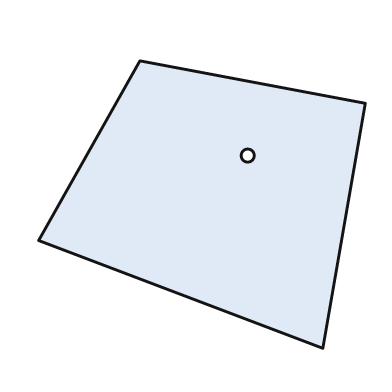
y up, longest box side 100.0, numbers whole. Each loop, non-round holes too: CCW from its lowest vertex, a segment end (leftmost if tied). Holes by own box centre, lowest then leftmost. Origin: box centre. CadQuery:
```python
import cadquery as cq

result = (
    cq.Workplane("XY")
    .moveTo(37.0, -44.0)
    .lineTo(50.0, 31.0)
    .lineTo(-19.0, 44.0)
    .lineTo(-50.0, -11.0)
    .close()
    .moveTo(14.0, 15.0)
    .circle(2.0)
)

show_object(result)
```